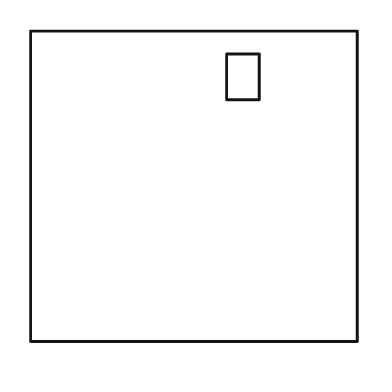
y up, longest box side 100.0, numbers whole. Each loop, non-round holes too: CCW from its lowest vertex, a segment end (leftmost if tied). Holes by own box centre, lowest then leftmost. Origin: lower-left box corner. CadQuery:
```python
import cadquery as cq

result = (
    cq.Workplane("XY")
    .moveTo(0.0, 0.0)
    .lineTo(100.0, 0.0)
    .lineTo(100.0, 95.0)
    .lineTo(0.0, 95.0)
    .close()
    .moveTo(60.0, 74.0)
    .lineTo(70.0, 74.0)
    .lineTo(70.0, 88.0)
    .lineTo(60.0, 88.0)
    .close()
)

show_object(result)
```